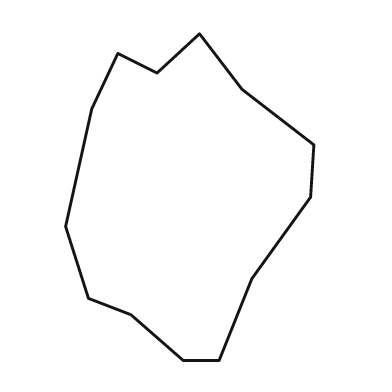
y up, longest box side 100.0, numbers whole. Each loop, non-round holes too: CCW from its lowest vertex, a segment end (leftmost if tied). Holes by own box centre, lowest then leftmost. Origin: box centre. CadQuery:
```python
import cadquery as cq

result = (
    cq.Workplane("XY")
    .moveTo(-2.0, -50.0)
    .lineTo(9.0, -50.0)
    .lineTo(19.0, -25.0)
    .lineTo(37.0, 0.0)
    .lineTo(38.0, 16.0)
    .lineTo(16.0, 33.0)
    .lineTo(3.0, 50.0)
    .lineTo(-10.0, 38.0)
    .lineTo(-22.0, 44.0)
    .lineTo(-30.0, 27.0)
    .lineTo(-38.0, -9.0)
    .lineTo(-31.0, -31.0)
    .lineTo(-18.0, -36.0)
    .close()
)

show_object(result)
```